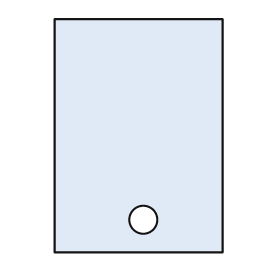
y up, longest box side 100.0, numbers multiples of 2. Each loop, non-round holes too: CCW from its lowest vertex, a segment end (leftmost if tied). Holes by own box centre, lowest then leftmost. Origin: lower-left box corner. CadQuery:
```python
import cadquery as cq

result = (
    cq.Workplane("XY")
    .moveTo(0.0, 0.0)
    .lineTo(72.0, 0.0)
    .lineTo(72.0, 100.0)
    .lineTo(0.0, 100.0)
    .close()
    .moveTo(38.0, 14.0)
    .circle(6.0)
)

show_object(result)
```